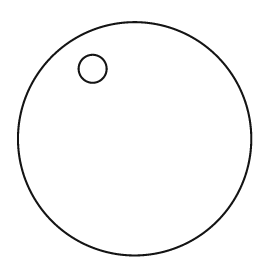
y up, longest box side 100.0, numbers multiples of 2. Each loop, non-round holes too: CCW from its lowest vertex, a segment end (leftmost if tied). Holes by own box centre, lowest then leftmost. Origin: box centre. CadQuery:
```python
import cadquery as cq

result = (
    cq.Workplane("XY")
    .moveTo(0.0, 0.0)
    .circle(50.0)
    .moveTo(-18.0, 30.0)
    .circle(6.0)
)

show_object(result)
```